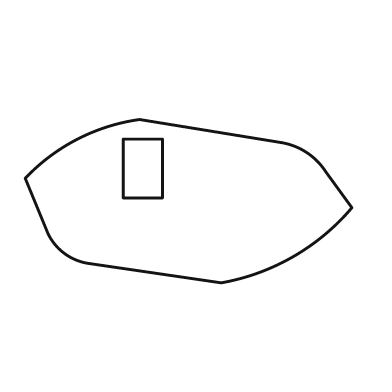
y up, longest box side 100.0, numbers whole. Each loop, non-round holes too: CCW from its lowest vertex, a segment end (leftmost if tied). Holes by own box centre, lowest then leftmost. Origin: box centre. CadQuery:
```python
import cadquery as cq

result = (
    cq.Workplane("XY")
    .moveTo(10.0, -25.0)
    .threePointArc((32.0, -17.0), (50.0, -2.0))
    .lineTo(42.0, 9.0)
    .threePointArc((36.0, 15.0), (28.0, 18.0))
    .lineTo(-15.0, 25.0)
    .threePointArc((-34.0, 19.0), (-50.0, 7.0))
    .lineTo(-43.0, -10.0)
    .threePointArc((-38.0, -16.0), (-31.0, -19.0))
    .close()
    .moveTo(-20.0, 1.0)
    .lineTo(-8.0, 1.0)
    .lineTo(-8.0, 19.0)
    .lineTo(-20.0, 19.0)
    .close()
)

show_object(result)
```